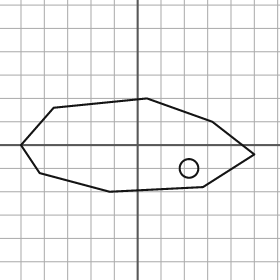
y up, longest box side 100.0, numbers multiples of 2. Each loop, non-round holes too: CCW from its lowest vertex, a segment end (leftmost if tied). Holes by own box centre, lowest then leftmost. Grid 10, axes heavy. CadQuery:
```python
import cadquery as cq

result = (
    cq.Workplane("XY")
    .moveTo(-12.0, -20.0)
    .lineTo(28.0, -18.0)
    .lineTo(50.0, -4.0)
    .lineTo(32.0, 10.0)
    .lineTo(4.0, 20.0)
    .lineTo(-36.0, 16.0)
    .lineTo(-50.0, 0.0)
    .lineTo(-42.0, -12.0)
    .close()
    .moveTo(22.0, -10.0)
    .circle(4.0)
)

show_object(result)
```